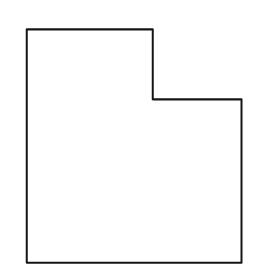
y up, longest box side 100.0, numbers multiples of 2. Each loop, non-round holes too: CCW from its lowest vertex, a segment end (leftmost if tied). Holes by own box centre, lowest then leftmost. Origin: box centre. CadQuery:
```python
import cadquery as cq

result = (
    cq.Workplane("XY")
    .moveTo(-46.0, -50.0)
    .lineTo(46.0, -50.0)
    .lineTo(46.0, 20.0)
    .lineTo(8.0, 20.0)
    .lineTo(8.0, 50.0)
    .lineTo(-46.0, 50.0)
    .close()
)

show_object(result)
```